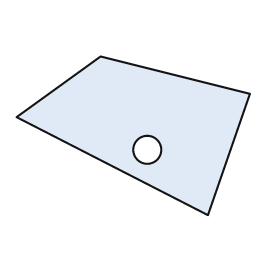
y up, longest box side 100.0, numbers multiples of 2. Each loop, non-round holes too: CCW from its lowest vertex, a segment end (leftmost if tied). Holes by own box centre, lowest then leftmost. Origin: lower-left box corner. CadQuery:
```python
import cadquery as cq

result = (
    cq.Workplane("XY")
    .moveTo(82.0, 0.0)
    .lineTo(100.0, 52.0)
    .lineTo(36.0, 68.0)
    .lineTo(0.0, 42.0)
    .close()
    .moveTo(56.0, 28.0)
    .circle(6.0)
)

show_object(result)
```